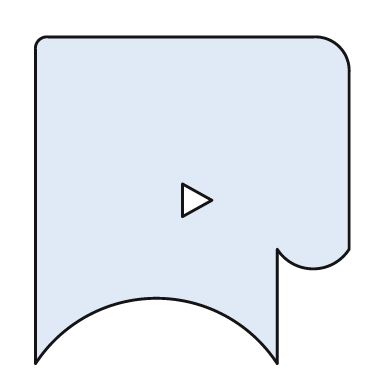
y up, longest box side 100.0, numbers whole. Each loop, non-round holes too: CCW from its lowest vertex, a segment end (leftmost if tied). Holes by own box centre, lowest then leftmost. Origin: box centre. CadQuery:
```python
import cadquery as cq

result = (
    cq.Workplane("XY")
    .moveTo(-48.0, -50.0)
    .threePointArc((-11.0, -30.0), (26.0, -50.0))
    .lineTo(26.0, -15.0)
    .threePointArc((37.0, -21.0), (48.0, -15.0))
    .lineTo(48.0, 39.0)
    .threePointArc((45.0, 47.0), (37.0, 50.0))
    .lineTo(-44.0, 50.0)
    .threePointArc((-47.0, 49.0), (-48.0, 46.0))
    .close()
    .moveTo(-3.0, -5.0)
    .lineTo(6.0, 0.0)
    .lineTo(-3.0, 5.0)
    .close()
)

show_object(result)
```